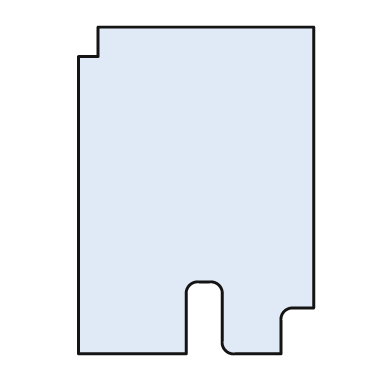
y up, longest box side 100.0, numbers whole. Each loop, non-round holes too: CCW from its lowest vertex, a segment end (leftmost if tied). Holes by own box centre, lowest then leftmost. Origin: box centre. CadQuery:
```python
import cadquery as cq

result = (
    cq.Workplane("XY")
    .moveTo(-36.0, -50.0)
    .lineTo(-3.0, -50.0)
    .lineTo(-3.0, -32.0)
    .threePointArc((-2.0, -29.0), (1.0, -28.0))
    .lineTo(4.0, -28.0)
    .threePointArc((7.0, -29.0), (8.0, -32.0))
    .lineTo(8.0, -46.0)
    .threePointArc((9.0, -49.0), (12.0, -50.0))
    .lineTo(26.0, -50.0)
    .lineTo(26.0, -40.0)
    .threePointArc((27.0, -37.0), (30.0, -36.0))
    .lineTo(36.0, -36.0)
    .lineTo(36.0, 50.0)
    .lineTo(-30.0, 50.0)
    .lineTo(-30.0, 41.0)
    .lineTo(-36.0, 41.0)
    .close()
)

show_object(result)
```